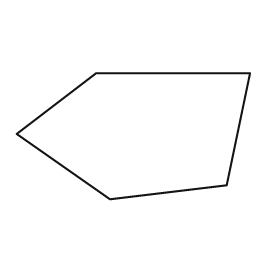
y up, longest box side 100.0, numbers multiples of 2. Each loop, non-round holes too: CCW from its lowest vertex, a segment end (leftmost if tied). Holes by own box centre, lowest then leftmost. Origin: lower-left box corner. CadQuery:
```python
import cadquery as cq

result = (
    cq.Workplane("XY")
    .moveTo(40.0, 0.0)
    .lineTo(90.0, 6.0)
    .lineTo(100.0, 54.0)
    .lineTo(34.0, 54.0)
    .lineTo(0.0, 28.0)
    .close()
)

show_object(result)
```